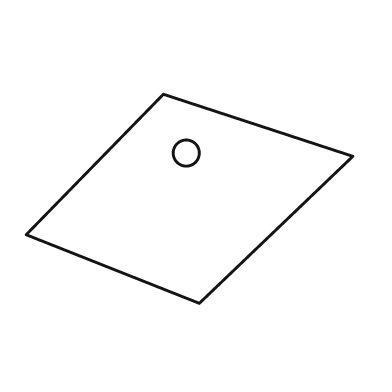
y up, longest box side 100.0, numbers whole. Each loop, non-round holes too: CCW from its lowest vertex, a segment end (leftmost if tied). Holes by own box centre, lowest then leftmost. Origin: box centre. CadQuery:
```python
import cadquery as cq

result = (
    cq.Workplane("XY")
    .moveTo(3.0, -32.0)
    .lineTo(50.0, 13.0)
    .lineTo(-8.0, 32.0)
    .lineTo(-50.0, -11.0)
    .close()
    .moveTo(-1.0, 14.0)
    .circle(4.0)
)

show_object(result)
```